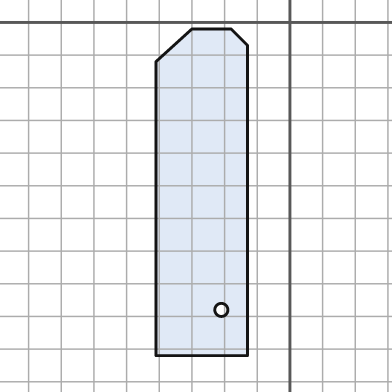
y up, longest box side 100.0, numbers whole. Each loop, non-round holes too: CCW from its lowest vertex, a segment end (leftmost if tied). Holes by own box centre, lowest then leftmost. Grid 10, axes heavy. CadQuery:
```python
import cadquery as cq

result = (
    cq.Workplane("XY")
    .moveTo(-41.0, -102.0)
    .lineTo(-13.0, -102.0)
    .lineTo(-13.0, -7.0)
    .lineTo(-18.0, -2.0)
    .lineTo(-30.0, -2.0)
    .lineTo(-41.0, -12.0)
    .close()
    .moveTo(-21.0, -88.0)
    .circle(2.0)
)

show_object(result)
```